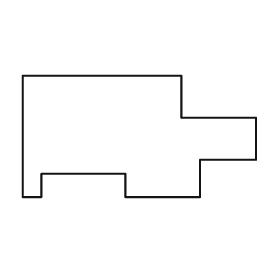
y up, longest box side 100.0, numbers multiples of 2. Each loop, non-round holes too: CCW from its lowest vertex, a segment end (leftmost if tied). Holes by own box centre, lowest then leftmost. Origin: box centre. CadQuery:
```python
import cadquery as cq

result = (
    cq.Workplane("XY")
    .moveTo(-50.0, -26.0)
    .lineTo(-42.0, -26.0)
    .lineTo(-42.0, -16.0)
    .lineTo(-6.0, -16.0)
    .lineTo(-6.0, -26.0)
    .lineTo(26.0, -26.0)
    .lineTo(26.0, -10.0)
    .lineTo(50.0, -10.0)
    .lineTo(50.0, 8.0)
    .lineTo(18.0, 8.0)
    .lineTo(18.0, 26.0)
    .lineTo(-50.0, 26.0)
    .close()
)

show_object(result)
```